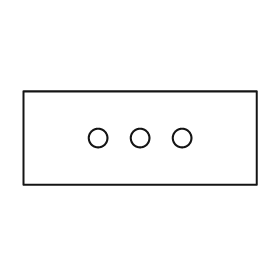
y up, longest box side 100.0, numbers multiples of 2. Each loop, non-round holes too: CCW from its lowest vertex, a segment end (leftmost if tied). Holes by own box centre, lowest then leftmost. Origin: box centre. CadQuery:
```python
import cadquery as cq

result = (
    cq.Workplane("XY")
    .moveTo(-50.0, -20.0)
    .lineTo(50.0, -20.0)
    .lineTo(50.0, 20.0)
    .lineTo(-50.0, 20.0)
    .close()
    .moveTo(-18.0, 0.0)
    .circle(4.0)
    .moveTo(0.0, 0.0)
    .circle(4.0)
    .moveTo(18.0, 0.0)
    .circle(4.0)
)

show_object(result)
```